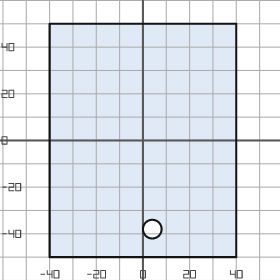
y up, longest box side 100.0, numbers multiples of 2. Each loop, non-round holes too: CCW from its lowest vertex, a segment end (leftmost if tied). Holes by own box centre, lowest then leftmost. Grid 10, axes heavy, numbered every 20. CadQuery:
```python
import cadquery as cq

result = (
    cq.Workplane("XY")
    .moveTo(-40.0, -50.0)
    .lineTo(40.0, -50.0)
    .lineTo(40.0, 50.0)
    .lineTo(-40.0, 50.0)
    .close()
    .moveTo(4.0, -38.0)
    .circle(4.0)
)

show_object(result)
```